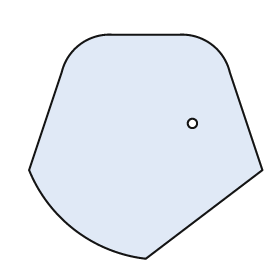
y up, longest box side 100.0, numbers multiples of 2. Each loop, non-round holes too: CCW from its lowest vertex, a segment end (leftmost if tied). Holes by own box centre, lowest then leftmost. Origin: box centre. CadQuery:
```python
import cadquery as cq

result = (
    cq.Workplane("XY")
    .moveTo(0.0, -48.0)
    .lineTo(50.0, -10.0)
    .lineTo(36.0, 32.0)
    .threePointArc((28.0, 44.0), (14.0, 48.0))
    .lineTo(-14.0, 48.0)
    .threePointArc((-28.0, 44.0), (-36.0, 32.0))
    .lineTo(-50.0, -10.0)
    .threePointArc((-30.0, -36.0), (0.0, -48.0))
    .close()
    .moveTo(20.0, 10.0)
    .circle(2.0)
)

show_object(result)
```